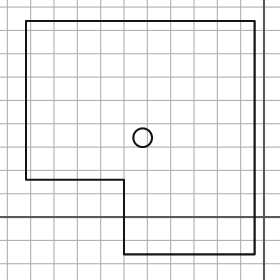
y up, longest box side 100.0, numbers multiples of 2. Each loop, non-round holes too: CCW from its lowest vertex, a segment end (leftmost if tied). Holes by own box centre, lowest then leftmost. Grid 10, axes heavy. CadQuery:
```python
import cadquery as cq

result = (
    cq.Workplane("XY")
    .moveTo(-60.0, -16.0)
    .lineTo(-4.0, -16.0)
    .lineTo(-4.0, 84.0)
    .lineTo(-102.0, 84.0)
    .lineTo(-102.0, 16.0)
    .lineTo(-60.0, 16.0)
    .close()
    .moveTo(-52.0, 34.0)
    .circle(4.0)
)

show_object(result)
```